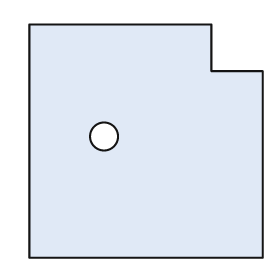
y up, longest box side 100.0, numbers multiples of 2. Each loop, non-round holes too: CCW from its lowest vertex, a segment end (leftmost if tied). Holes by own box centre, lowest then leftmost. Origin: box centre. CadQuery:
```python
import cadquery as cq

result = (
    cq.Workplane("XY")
    .moveTo(-50.0, -50.0)
    .lineTo(50.0, -50.0)
    .lineTo(50.0, 30.0)
    .lineTo(28.0, 30.0)
    .lineTo(28.0, 50.0)
    .lineTo(-50.0, 50.0)
    .close()
    .moveTo(-18.0, 2.0)
    .circle(6.0)
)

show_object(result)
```